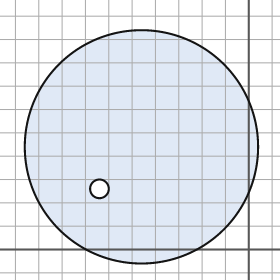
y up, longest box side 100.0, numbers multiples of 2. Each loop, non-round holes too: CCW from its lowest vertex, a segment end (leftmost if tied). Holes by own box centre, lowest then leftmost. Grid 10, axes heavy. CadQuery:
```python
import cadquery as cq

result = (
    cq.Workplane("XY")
    .moveTo(-46.0, 44.0)
    .circle(50.0)
    .moveTo(-64.0, 26.0)
    .circle(4.0)
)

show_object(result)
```